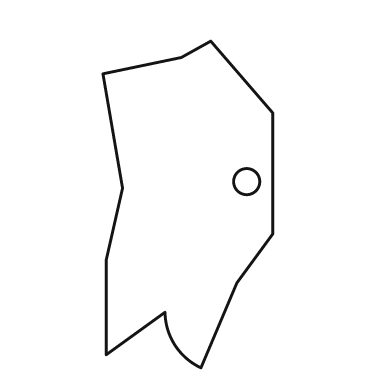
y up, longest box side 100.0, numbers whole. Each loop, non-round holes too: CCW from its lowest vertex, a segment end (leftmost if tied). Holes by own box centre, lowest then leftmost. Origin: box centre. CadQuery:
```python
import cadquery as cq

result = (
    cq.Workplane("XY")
    .moveTo(4.0, -50.0)
    .lineTo(15.0, -24.0)
    .lineTo(26.0, -9.0)
    .lineTo(26.0, 28.0)
    .lineTo(7.0, 50.0)
    .lineTo(-2.0, 45.0)
    .lineTo(-26.0, 40.0)
    .lineTo(-20.0, 5.0)
    .lineTo(-25.0, -17.0)
    .lineTo(-25.0, -46.0)
    .lineTo(-7.0, -33.0)
    .threePointArc((-4.0, -43.0), (4.0, -50.0))
    .close()
    .moveTo(18.0, 7.0)
    .circle(4.0)
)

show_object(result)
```